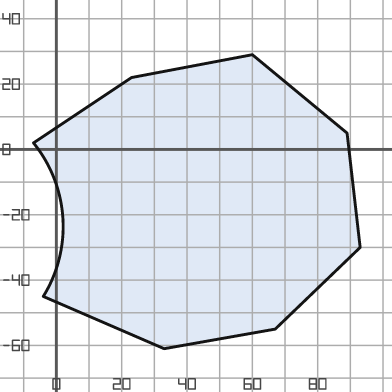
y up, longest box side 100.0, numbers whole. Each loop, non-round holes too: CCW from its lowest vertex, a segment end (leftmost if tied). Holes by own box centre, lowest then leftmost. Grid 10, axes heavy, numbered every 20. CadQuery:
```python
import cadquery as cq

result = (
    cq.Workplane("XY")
    .moveTo(33.0, -61.0)
    .lineTo(67.0, -55.0)
    .lineTo(93.0, -30.0)
    .lineTo(89.0, 5.0)
    .lineTo(60.0, 29.0)
    .lineTo(23.0, 22.0)
    .lineTo(-7.0, 2.0)
    .threePointArc((2.0, -21.0), (-4.0, -45.0))
    .close()
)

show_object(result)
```